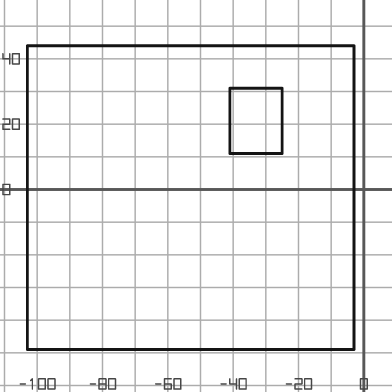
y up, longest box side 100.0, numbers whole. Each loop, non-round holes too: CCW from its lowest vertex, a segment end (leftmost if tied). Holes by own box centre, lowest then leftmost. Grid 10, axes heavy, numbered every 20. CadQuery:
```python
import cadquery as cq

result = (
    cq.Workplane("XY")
    .moveTo(-103.0, -49.0)
    .lineTo(-3.0, -49.0)
    .lineTo(-3.0, 44.0)
    .lineTo(-103.0, 44.0)
    .close()
    .moveTo(-41.0, 11.0)
    .lineTo(-25.0, 11.0)
    .lineTo(-25.0, 31.0)
    .lineTo(-41.0, 31.0)
    .close()
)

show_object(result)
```